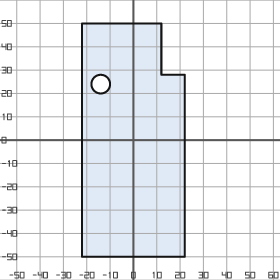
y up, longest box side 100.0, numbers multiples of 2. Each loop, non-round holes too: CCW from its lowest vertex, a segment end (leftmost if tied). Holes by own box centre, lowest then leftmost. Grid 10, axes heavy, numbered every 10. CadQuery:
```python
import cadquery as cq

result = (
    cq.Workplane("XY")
    .moveTo(-22.0, -50.0)
    .lineTo(22.0, -50.0)
    .lineTo(22.0, 28.0)
    .lineTo(12.0, 28.0)
    .lineTo(12.0, 50.0)
    .lineTo(-22.0, 50.0)
    .close()
    .moveTo(-14.0, 24.0)
    .circle(4.0)
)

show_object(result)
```